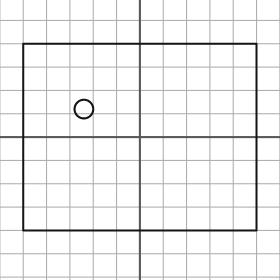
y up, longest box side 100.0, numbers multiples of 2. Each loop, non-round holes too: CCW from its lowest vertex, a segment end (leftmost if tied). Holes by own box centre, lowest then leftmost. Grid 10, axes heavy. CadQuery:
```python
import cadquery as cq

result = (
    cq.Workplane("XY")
    .moveTo(-50.0, -40.0)
    .lineTo(50.0, -40.0)
    .lineTo(50.0, 40.0)
    .lineTo(-50.0, 40.0)
    .close()
    .moveTo(-24.0, 12.0)
    .circle(4.0)
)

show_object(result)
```